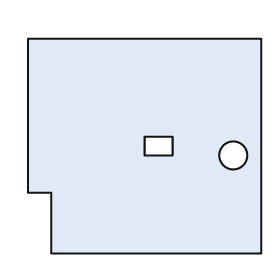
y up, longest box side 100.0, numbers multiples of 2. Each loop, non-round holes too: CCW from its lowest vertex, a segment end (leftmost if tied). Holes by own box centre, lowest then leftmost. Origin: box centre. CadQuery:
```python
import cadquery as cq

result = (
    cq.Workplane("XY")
    .moveTo(-40.0, -46.0)
    .lineTo(50.0, -46.0)
    .lineTo(50.0, 46.0)
    .lineTo(-50.0, 46.0)
    .lineTo(-50.0, -20.0)
    .lineTo(-40.0, -20.0)
    .close()
    .moveTo(38.0, -4.0)
    .circle(6.0)
    .moveTo(0.0, -4.0)
    .lineTo(12.0, -4.0)
    .lineTo(12.0, 4.0)
    .lineTo(0.0, 4.0)
    .close()
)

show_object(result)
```